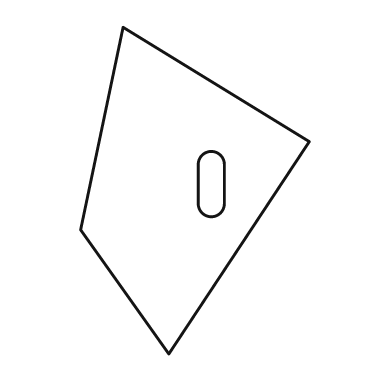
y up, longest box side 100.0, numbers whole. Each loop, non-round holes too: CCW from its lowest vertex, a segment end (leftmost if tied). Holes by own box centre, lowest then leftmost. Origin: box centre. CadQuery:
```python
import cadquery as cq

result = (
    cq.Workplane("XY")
    .moveTo(-8.0, -50.0)
    .lineTo(35.0, 15.0)
    .lineTo(-22.0, 50.0)
    .lineTo(-35.0, -12.0)
    .close()
    .moveTo(1.0, -4.0)
    .threePointArc((5.0, -8.0), (9.0, -4.0))
    .lineTo(9.0, 8.0)
    .threePointArc((5.0, 12.0), (1.0, 8.0))
    .close()
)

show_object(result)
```